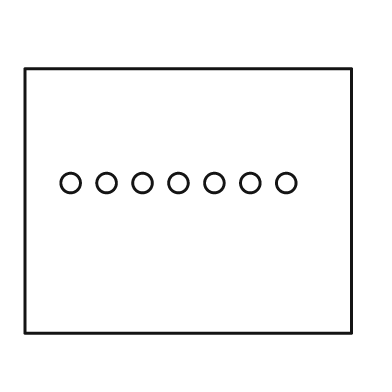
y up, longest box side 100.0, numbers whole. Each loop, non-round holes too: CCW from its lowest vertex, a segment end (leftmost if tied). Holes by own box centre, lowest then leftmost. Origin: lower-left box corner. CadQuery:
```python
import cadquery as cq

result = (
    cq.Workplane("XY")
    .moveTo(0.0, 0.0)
    .lineTo(100.0, 0.0)
    .lineTo(100.0, 81.0)
    .lineTo(0.0, 81.0)
    .close()
    .moveTo(14.0, 46.0)
    .circle(3.0)
    .moveTo(25.0, 46.0)
    .circle(3.0)
    .moveTo(36.0, 46.0)
    .circle(3.0)
    .moveTo(47.0, 46.0)
    .circle(3.0)
    .moveTo(58.0, 46.0)
    .circle(3.0)
    .moveTo(69.0, 46.0)
    .circle(3.0)
    .moveTo(80.0, 46.0)
    .circle(3.0)
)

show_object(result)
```